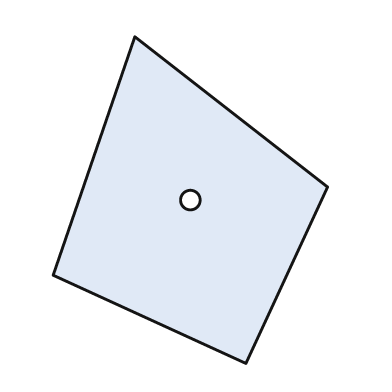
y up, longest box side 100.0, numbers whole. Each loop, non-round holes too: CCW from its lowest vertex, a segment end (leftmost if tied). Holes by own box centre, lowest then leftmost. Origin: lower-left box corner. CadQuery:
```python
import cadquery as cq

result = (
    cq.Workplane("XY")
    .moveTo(59.0, 0.0)
    .lineTo(84.0, 54.0)
    .lineTo(25.0, 100.0)
    .lineTo(0.0, 27.0)
    .close()
    .moveTo(42.0, 50.0)
    .circle(3.0)
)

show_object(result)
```